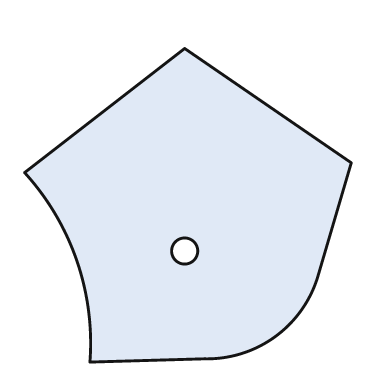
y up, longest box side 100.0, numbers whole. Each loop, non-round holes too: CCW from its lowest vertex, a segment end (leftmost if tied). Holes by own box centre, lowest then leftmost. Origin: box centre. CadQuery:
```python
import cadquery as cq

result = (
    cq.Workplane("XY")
    .moveTo(-30.0, -48.0)
    .lineTo(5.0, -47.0)
    .threePointArc((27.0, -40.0), (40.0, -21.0))
    .lineTo(50.0, 13.0)
    .lineTo(-1.0, 48.0)
    .lineTo(-50.0, 10.0)
    .threePointArc((-34.0, -17.0), (-30.0, -48.0))
    .close()
    .moveTo(-1.0, -14.0)
    .circle(4.0)
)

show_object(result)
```